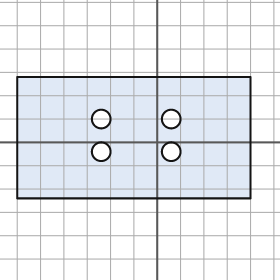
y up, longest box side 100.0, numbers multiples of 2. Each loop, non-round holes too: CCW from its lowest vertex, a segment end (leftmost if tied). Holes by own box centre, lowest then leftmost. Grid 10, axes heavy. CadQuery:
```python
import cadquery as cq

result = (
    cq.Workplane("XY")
    .moveTo(-60.0, -24.0)
    .lineTo(40.0, -24.0)
    .lineTo(40.0, 28.0)
    .lineTo(-60.0, 28.0)
    .close()
    .moveTo(-24.0, -4.0)
    .circle(4.0)
    .moveTo(6.0, -4.0)
    .circle(4.0)
    .moveTo(-24.0, 10.0)
    .circle(4.0)
    .moveTo(6.0, 10.0)
    .circle(4.0)
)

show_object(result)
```